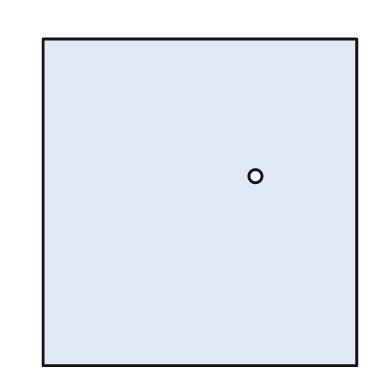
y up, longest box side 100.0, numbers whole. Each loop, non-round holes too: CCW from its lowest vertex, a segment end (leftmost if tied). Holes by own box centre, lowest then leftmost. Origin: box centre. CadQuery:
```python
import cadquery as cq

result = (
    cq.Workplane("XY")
    .moveTo(-48.0, -50.0)
    .lineTo(48.0, -50.0)
    .lineTo(48.0, 50.0)
    .lineTo(-48.0, 50.0)
    .close()
    .moveTo(17.0, 8.0)
    .circle(2.0)
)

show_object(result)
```